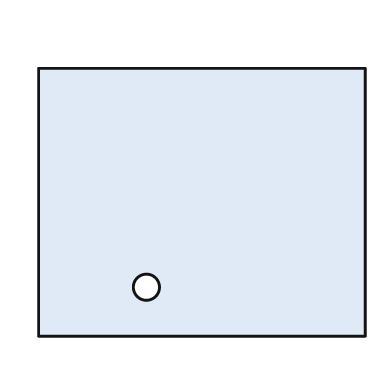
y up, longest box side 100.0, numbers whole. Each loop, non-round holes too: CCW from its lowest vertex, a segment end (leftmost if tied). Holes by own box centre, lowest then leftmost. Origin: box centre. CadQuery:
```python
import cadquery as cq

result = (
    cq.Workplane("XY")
    .moveTo(-50.0, -41.0)
    .lineTo(50.0, -41.0)
    .lineTo(50.0, 41.0)
    .lineTo(-50.0, 41.0)
    .close()
    .moveTo(-17.0, -26.0)
    .circle(4.0)
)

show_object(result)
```